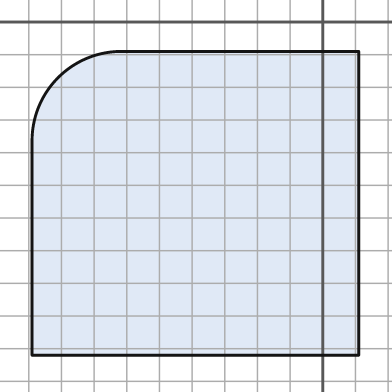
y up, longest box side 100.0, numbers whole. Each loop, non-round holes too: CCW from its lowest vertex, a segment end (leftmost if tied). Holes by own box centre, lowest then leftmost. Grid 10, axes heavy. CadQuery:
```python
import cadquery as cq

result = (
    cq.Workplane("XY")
    .moveTo(-89.0, -102.0)
    .lineTo(11.0, -102.0)
    .lineTo(11.0, -9.0)
    .lineTo(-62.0, -9.0)
    .threePointArc((-81.0, -17.0), (-89.0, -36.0))
    .close()
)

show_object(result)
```